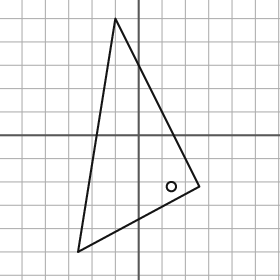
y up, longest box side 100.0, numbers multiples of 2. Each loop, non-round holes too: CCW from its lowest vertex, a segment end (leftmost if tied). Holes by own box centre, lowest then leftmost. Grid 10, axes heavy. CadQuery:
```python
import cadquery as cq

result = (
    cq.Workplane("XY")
    .moveTo(-26.0, -50.0)
    .lineTo(26.0, -22.0)
    .lineTo(-10.0, 50.0)
    .close()
    .moveTo(14.0, -22.0)
    .circle(2.0)
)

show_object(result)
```